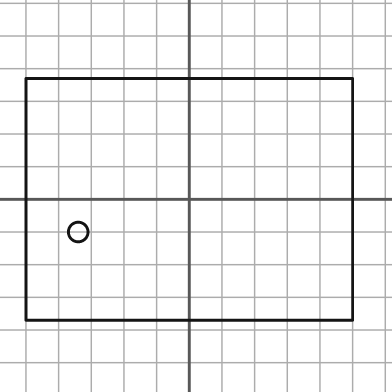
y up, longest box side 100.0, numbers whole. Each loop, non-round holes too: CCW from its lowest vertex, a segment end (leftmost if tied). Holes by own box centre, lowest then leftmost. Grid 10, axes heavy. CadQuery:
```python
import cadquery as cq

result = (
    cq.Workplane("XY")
    .moveTo(-50.0, -37.0)
    .lineTo(50.0, -37.0)
    .lineTo(50.0, 37.0)
    .lineTo(-50.0, 37.0)
    .close()
    .moveTo(-34.0, -10.0)
    .circle(3.0)
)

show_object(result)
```